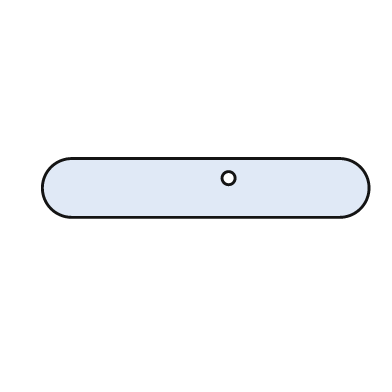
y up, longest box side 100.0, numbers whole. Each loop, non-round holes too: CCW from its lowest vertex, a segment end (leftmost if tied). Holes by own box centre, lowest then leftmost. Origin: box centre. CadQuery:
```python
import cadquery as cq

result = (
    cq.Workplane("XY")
    .moveTo(-41.0, -9.0)
    .lineTo(41.0, -9.0)
    .threePointArc((50.0, 0.0), (41.0, 9.0))
    .lineTo(-41.0, 9.0)
    .threePointArc((-50.0, 0.0), (-41.0, -9.0))
    .close()
    .moveTo(7.0, 3.0)
    .circle(2.0)
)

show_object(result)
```